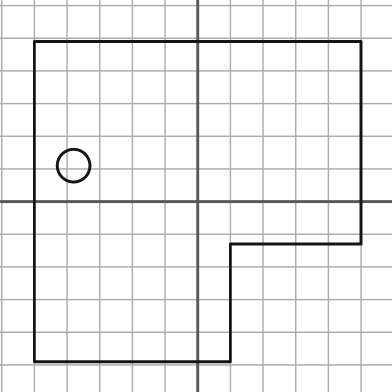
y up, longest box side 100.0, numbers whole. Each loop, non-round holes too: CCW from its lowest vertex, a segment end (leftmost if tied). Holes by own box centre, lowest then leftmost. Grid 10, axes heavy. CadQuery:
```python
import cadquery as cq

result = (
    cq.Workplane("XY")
    .moveTo(-50.0, -49.0)
    .lineTo(10.0, -49.0)
    .lineTo(10.0, -13.0)
    .lineTo(50.0, -13.0)
    .lineTo(50.0, 49.0)
    .lineTo(-50.0, 49.0)
    .close()
    .moveTo(-38.0, 11.0)
    .circle(5.0)
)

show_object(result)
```